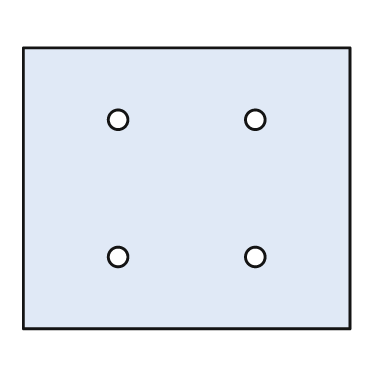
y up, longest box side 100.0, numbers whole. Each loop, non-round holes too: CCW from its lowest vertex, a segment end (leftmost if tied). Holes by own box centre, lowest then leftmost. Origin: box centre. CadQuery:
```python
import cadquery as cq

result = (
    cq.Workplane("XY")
    .moveTo(-50.0, -43.0)
    .lineTo(50.0, -43.0)
    .lineTo(50.0, 43.0)
    .lineTo(-50.0, 43.0)
    .close()
    .moveTo(-21.0, -21.0)
    .circle(3.0)
    .moveTo(21.0, -21.0)
    .circle(3.0)
    .moveTo(-21.0, 21.0)
    .circle(3.0)
    .moveTo(21.0, 21.0)
    .circle(3.0)
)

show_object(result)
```